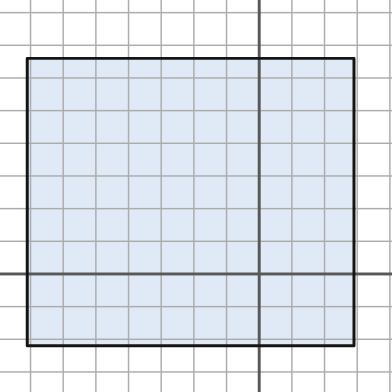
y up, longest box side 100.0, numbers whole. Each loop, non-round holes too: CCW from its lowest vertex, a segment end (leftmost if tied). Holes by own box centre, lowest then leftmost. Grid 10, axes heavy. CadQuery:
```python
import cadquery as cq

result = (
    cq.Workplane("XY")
    .moveTo(-71.0, -22.0)
    .lineTo(29.0, -22.0)
    .lineTo(29.0, 66.0)
    .lineTo(-71.0, 66.0)
    .close()
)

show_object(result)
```